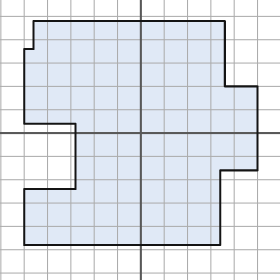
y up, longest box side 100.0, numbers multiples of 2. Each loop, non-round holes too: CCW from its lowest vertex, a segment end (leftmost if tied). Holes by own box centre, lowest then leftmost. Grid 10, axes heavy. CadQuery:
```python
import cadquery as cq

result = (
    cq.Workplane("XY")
    .moveTo(-50.0, -48.0)
    .lineTo(34.0, -48.0)
    .lineTo(34.0, -16.0)
    .lineTo(50.0, -16.0)
    .lineTo(50.0, 20.0)
    .lineTo(36.0, 20.0)
    .lineTo(36.0, 48.0)
    .lineTo(-46.0, 48.0)
    .lineTo(-46.0, 36.0)
    .lineTo(-50.0, 36.0)
    .lineTo(-50.0, 4.0)
    .lineTo(-28.0, 4.0)
    .lineTo(-28.0, -24.0)
    .lineTo(-50.0, -24.0)
    .close()
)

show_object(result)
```